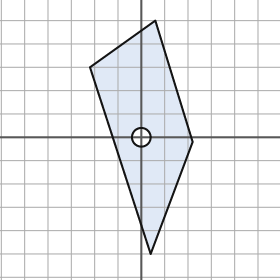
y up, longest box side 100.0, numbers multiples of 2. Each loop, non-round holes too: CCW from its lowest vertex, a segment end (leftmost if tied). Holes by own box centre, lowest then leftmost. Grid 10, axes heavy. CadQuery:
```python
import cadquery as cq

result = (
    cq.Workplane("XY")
    .moveTo(4.0, -50.0)
    .lineTo(22.0, -2.0)
    .lineTo(6.0, 50.0)
    .lineTo(-22.0, 30.0)
    .close()
    .moveTo(0.0, 0.0)
    .circle(4.0)
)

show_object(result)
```